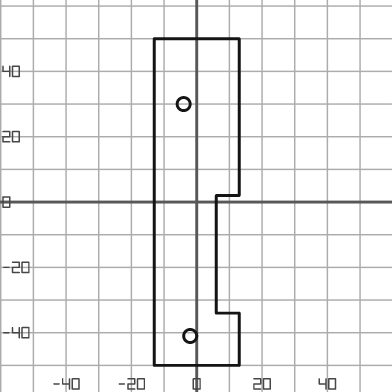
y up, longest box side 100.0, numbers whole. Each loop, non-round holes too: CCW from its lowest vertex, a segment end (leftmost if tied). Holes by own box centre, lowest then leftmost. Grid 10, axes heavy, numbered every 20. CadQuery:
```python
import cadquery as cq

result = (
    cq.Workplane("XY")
    .moveTo(-13.0, -50.0)
    .lineTo(13.0, -50.0)
    .lineTo(13.0, -34.0)
    .lineTo(6.0, -34.0)
    .lineTo(6.0, 2.0)
    .lineTo(13.0, 2.0)
    .lineTo(13.0, 50.0)
    .lineTo(-13.0, 50.0)
    .close()
    .moveTo(-2.0, -41.0)
    .circle(2.0)
    .moveTo(-4.0, 30.0)
    .circle(2.0)
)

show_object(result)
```